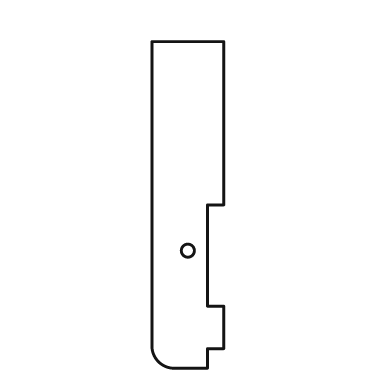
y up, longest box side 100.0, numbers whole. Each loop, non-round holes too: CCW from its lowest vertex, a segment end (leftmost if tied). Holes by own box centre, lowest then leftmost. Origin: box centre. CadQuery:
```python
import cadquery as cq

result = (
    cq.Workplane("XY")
    .moveTo(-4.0, -50.0)
    .lineTo(6.0, -50.0)
    .lineTo(6.0, -44.0)
    .lineTo(11.0, -44.0)
    .lineTo(11.0, -31.0)
    .lineTo(6.0, -31.0)
    .lineTo(6.0, 0.0)
    .lineTo(11.0, 0.0)
    .lineTo(11.0, 50.0)
    .lineTo(-11.0, 50.0)
    .lineTo(-11.0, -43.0)
    .threePointArc((-9.0, -48.0), (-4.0, -50.0))
    .close()
    .moveTo(0.0, -14.0)
    .circle(2.0)
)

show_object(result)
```